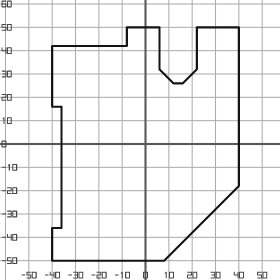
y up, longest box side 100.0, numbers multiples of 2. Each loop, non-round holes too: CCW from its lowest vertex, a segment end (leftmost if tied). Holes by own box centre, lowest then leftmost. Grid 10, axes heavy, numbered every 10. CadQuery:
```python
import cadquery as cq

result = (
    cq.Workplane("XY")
    .moveTo(-40.0, -50.0)
    .lineTo(8.0, -50.0)
    .lineTo(40.0, -18.0)
    .lineTo(40.0, 50.0)
    .lineTo(22.0, 50.0)
    .lineTo(22.0, 32.0)
    .lineTo(16.0, 26.0)
    .lineTo(12.0, 26.0)
    .lineTo(6.0, 32.0)
    .lineTo(6.0, 50.0)
    .lineTo(-8.0, 50.0)
    .lineTo(-8.0, 42.0)
    .lineTo(-40.0, 42.0)
    .lineTo(-40.0, 16.0)
    .lineTo(-36.0, 16.0)
    .lineTo(-36.0, -36.0)
    .lineTo(-40.0, -36.0)
    .close()
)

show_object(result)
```